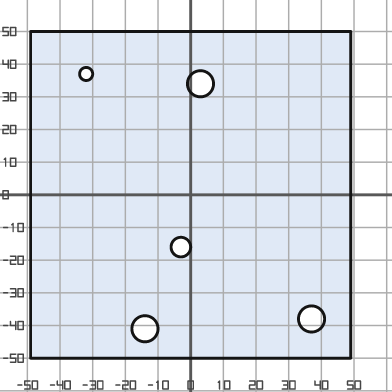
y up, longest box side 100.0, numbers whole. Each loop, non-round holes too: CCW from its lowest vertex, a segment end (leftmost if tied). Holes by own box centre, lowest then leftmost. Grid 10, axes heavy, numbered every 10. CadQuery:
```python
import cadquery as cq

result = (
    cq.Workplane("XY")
    .moveTo(-49.0, -50.0)
    .lineTo(49.0, -50.0)
    .lineTo(49.0, 50.0)
    .lineTo(-49.0, 50.0)
    .close()
    .moveTo(-14.0, -41.0)
    .circle(4.0)
    .moveTo(37.0, -38.0)
    .circle(4.0)
    .moveTo(-3.0, -16.0)
    .circle(3.0)
    .moveTo(3.0, 34.0)
    .circle(4.0)
    .moveTo(-32.0, 37.0)
    .circle(2.0)
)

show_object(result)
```